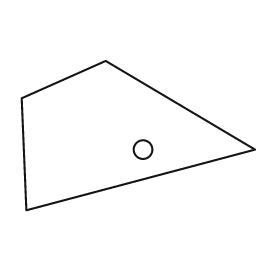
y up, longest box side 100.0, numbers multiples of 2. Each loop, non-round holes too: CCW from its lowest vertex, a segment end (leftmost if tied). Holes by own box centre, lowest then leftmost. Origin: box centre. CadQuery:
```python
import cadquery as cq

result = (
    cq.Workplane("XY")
    .moveTo(-48.0, -32.0)
    .lineTo(50.0, -6.0)
    .lineTo(-14.0, 32.0)
    .lineTo(-50.0, 16.0)
    .close()
    .moveTo(2.0, -6.0)
    .circle(4.0)
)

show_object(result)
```